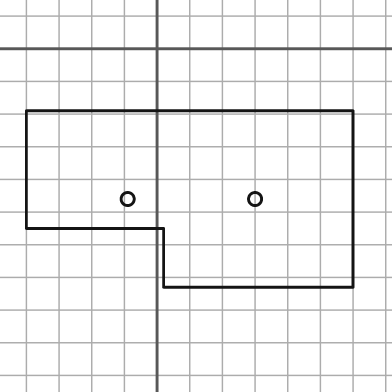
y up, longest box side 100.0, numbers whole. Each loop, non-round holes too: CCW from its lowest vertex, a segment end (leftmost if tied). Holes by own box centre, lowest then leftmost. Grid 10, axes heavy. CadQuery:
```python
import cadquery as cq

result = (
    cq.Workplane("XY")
    .moveTo(2.0, -73.0)
    .lineTo(60.0, -73.0)
    .lineTo(60.0, -19.0)
    .lineTo(-40.0, -19.0)
    .lineTo(-40.0, -55.0)
    .lineTo(2.0, -55.0)
    .close()
    .moveTo(-9.0, -46.0)
    .circle(2.0)
    .moveTo(30.0, -46.0)
    .circle(2.0)
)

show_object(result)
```